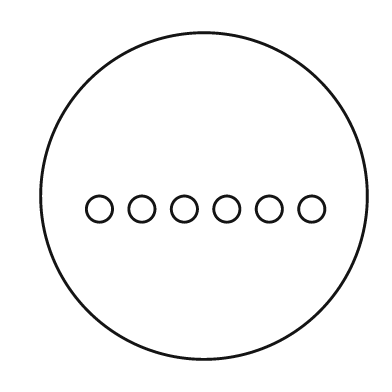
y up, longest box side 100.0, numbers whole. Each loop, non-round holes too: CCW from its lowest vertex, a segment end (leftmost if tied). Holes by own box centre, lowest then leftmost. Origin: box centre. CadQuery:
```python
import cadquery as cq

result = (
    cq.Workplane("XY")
    .moveTo(0.0, 0.0)
    .circle(50.0)
    .moveTo(-32.0, -4.0)
    .circle(4.0)
    .moveTo(-19.0, -4.0)
    .circle(4.0)
    .moveTo(-6.0, -4.0)
    .circle(4.0)
    .moveTo(7.0, -4.0)
    .circle(4.0)
    .moveTo(20.0, -4.0)
    .circle(4.0)
    .moveTo(33.0, -4.0)
    .circle(4.0)
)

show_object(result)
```